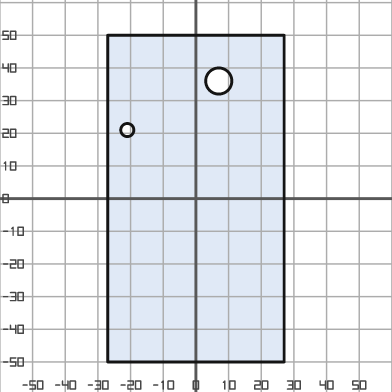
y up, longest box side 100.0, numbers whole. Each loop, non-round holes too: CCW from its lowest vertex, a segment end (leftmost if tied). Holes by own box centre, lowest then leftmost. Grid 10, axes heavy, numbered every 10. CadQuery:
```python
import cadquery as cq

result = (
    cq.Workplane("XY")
    .moveTo(-27.0, -50.0)
    .lineTo(27.0, -50.0)
    .lineTo(27.0, 50.0)
    .lineTo(-27.0, 50.0)
    .close()
    .moveTo(-21.0, 21.0)
    .circle(2.0)
    .moveTo(7.0, 36.0)
    .circle(4.0)
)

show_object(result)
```